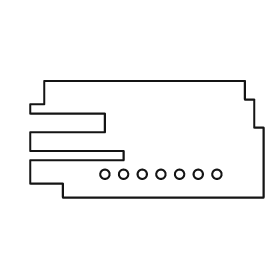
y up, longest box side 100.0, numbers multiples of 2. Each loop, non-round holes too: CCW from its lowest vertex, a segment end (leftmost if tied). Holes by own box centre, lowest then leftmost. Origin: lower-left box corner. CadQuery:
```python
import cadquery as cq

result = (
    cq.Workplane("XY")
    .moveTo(14.0, 0.0)
    .lineTo(100.0, 0.0)
    .lineTo(100.0, 30.0)
    .lineTo(96.0, 30.0)
    .lineTo(96.0, 42.0)
    .lineTo(92.0, 42.0)
    .lineTo(92.0, 50.0)
    .lineTo(6.0, 50.0)
    .lineTo(6.0, 40.0)
    .lineTo(0.0, 40.0)
    .lineTo(0.0, 36.0)
    .lineTo(32.0, 36.0)
    .lineTo(32.0, 28.0)
    .lineTo(0.0, 28.0)
    .lineTo(0.0, 20.0)
    .lineTo(40.0, 20.0)
    .lineTo(40.0, 16.0)
    .lineTo(0.0, 16.0)
    .lineTo(0.0, 6.0)
    .lineTo(14.0, 6.0)
    .close()
    .moveTo(32.0, 10.0)
    .circle(2.0)
    .moveTo(40.0, 10.0)
    .circle(2.0)
    .moveTo(48.0, 10.0)
    .circle(2.0)
    .moveTo(56.0, 10.0)
    .circle(2.0)
    .moveTo(64.0, 10.0)
    .circle(2.0)
    .moveTo(72.0, 10.0)
    .circle(2.0)
    .moveTo(80.0, 10.0)
    .circle(2.0)
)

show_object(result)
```